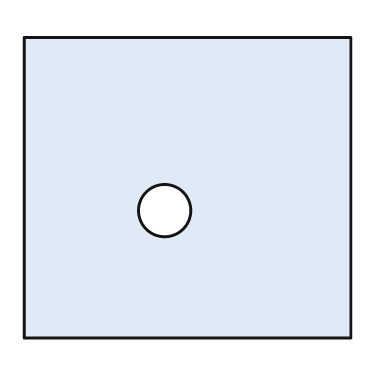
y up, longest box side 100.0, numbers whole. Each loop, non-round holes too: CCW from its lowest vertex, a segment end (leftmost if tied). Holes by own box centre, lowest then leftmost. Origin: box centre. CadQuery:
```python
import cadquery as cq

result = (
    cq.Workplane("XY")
    .moveTo(-50.0, -46.0)
    .lineTo(50.0, -46.0)
    .lineTo(50.0, 46.0)
    .lineTo(-50.0, 46.0)
    .close()
    .moveTo(-7.0, -7.0)
    .circle(8.0)
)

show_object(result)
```